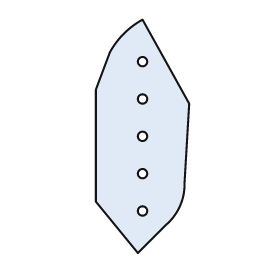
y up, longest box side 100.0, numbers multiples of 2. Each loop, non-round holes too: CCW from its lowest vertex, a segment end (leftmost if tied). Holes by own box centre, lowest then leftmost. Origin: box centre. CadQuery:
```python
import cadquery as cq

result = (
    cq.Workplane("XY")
    .moveTo(-2.0, -50.0)
    .lineTo(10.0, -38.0)
    .threePointArc((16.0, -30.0), (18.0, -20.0))
    .lineTo(20.0, 14.0)
    .lineTo(0.0, 50.0)
    .threePointArc((-8.0, 44.0), (-14.0, 36.0))
    .lineTo(-20.0, 20.0)
    .lineTo(-20.0, -28.0)
    .close()
    .moveTo(0.0, -32.0)
    .circle(2.0)
    .moveTo(0.0, -16.0)
    .circle(2.0)
    .moveTo(0.0, 0.0)
    .circle(2.0)
    .moveTo(0.0, 16.0)
    .circle(2.0)
    .moveTo(0.0, 32.0)
    .circle(2.0)
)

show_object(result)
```